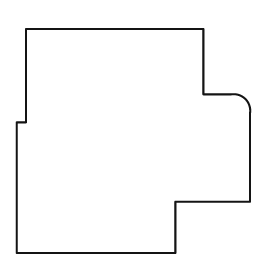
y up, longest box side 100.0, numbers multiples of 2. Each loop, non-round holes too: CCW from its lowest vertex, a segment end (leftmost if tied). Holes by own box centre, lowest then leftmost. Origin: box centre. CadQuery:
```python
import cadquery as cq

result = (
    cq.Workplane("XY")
    .moveTo(-50.0, -48.0)
    .lineTo(18.0, -48.0)
    .lineTo(18.0, -26.0)
    .lineTo(50.0, -26.0)
    .lineTo(50.0, 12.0)
    .threePointArc((48.0, 18.0), (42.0, 20.0))
    .lineTo(30.0, 20.0)
    .lineTo(30.0, 48.0)
    .lineTo(-46.0, 48.0)
    .lineTo(-46.0, 8.0)
    .lineTo(-50.0, 8.0)
    .close()
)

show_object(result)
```